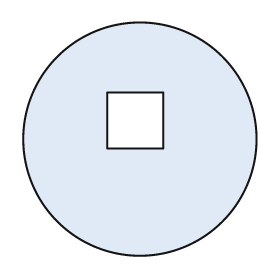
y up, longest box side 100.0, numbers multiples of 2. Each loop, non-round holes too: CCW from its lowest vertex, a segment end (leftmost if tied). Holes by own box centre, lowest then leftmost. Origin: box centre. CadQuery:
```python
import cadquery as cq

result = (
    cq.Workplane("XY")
    .moveTo(0.0, 0.0)
    .circle(50.0)
    .moveTo(-14.0, -4.0)
    .lineTo(10.0, -4.0)
    .lineTo(10.0, 20.0)
    .lineTo(-14.0, 20.0)
    .close()
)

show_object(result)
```